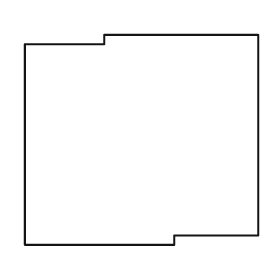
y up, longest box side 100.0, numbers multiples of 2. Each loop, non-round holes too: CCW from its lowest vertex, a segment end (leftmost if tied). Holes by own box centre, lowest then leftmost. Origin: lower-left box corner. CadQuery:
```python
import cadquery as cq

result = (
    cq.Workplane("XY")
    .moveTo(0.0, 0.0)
    .lineTo(64.0, 0.0)
    .lineTo(64.0, 4.0)
    .lineTo(100.0, 4.0)
    .lineTo(100.0, 90.0)
    .lineTo(34.0, 90.0)
    .lineTo(34.0, 86.0)
    .lineTo(0.0, 86.0)
    .close()
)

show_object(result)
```